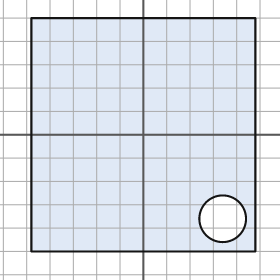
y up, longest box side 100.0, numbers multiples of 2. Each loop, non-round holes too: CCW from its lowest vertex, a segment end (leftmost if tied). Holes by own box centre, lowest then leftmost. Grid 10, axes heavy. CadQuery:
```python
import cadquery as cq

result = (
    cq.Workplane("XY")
    .moveTo(-48.0, -50.0)
    .lineTo(48.0, -50.0)
    .lineTo(48.0, 50.0)
    .lineTo(-48.0, 50.0)
    .close()
    .moveTo(34.0, -36.0)
    .circle(10.0)
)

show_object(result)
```